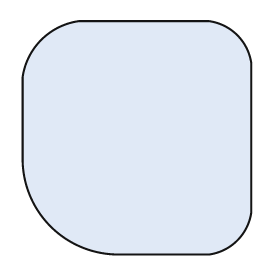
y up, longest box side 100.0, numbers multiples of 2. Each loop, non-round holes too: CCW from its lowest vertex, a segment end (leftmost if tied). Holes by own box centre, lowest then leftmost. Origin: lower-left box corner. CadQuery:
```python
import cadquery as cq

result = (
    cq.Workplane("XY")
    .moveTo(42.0, 0.0)
    .lineTo(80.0, 0.0)
    .threePointArc((92.0, 6.0), (98.0, 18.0))
    .lineTo(98.0, 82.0)
    .threePointArc((92.0, 94.0), (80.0, 100.0))
    .lineTo(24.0, 100.0)
    .threePointArc((8.0, 92.0), (0.0, 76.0))
    .lineTo(0.0, 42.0)
    .threePointArc((12.0, 12.0), (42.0, 0.0))
    .close()
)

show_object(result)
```